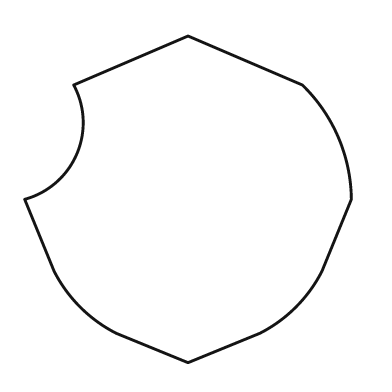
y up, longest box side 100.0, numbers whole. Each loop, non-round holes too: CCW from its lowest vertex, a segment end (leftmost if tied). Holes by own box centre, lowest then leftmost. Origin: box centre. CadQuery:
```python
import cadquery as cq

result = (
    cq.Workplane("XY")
    .moveTo(0.0, -50.0)
    .lineTo(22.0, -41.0)
    .threePointArc((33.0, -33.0), (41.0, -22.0))
    .lineTo(50.0, 0.0)
    .threePointArc((46.0, 19.0), (35.0, 35.0))
    .lineTo(0.0, 50.0)
    .lineTo(-35.0, 35.0)
    .threePointArc((-34.0, 14.0), (-50.0, 0.0))
    .lineTo(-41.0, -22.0)
    .threePointArc((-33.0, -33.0), (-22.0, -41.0))
    .close()
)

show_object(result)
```